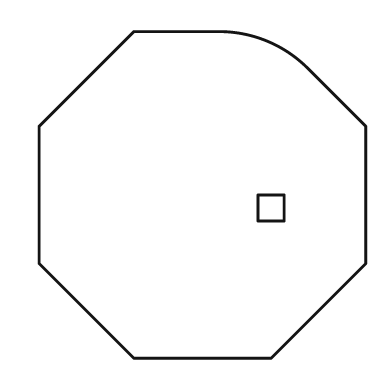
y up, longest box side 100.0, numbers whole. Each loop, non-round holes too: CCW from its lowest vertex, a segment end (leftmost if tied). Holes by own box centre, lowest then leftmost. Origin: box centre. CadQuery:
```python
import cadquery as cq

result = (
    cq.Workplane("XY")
    .moveTo(-21.0, -50.0)
    .lineTo(21.0, -50.0)
    .lineTo(50.0, -21.0)
    .lineTo(50.0, 21.0)
    .lineTo(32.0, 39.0)
    .threePointArc((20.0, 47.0), (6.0, 50.0))
    .lineTo(-21.0, 50.0)
    .lineTo(-50.0, 21.0)
    .lineTo(-50.0, -21.0)
    .close()
    .moveTo(17.0, -8.0)
    .lineTo(25.0, -8.0)
    .lineTo(25.0, 0.0)
    .lineTo(17.0, 0.0)
    .close()
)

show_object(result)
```